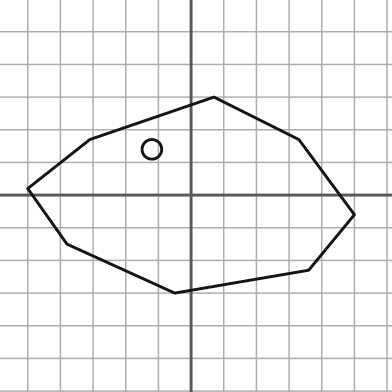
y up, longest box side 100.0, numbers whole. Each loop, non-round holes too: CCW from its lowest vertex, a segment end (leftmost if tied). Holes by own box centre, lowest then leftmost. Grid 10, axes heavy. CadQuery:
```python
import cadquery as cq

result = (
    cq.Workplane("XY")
    .moveTo(-5.0, -30.0)
    .lineTo(36.0, -23.0)
    .lineTo(50.0, -6.0)
    .lineTo(33.0, 17.0)
    .lineTo(7.0, 30.0)
    .lineTo(-31.0, 17.0)
    .lineTo(-50.0, 2.0)
    .lineTo(-38.0, -15.0)
    .close()
    .moveTo(-12.0, 14.0)
    .circle(3.0)
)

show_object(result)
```